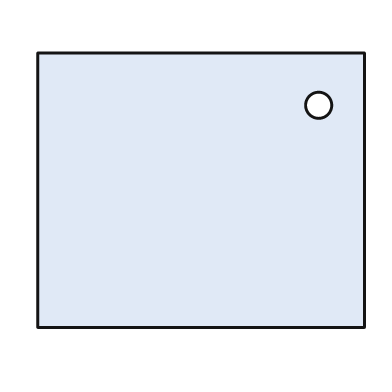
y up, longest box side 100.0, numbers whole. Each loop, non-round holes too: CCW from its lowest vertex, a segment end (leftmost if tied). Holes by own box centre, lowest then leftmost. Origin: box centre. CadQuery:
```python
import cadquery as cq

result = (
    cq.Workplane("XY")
    .moveTo(-50.0, -42.0)
    .lineTo(50.0, -42.0)
    .lineTo(50.0, 42.0)
    .lineTo(-50.0, 42.0)
    .close()
    .moveTo(36.0, 26.0)
    .circle(4.0)
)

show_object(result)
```